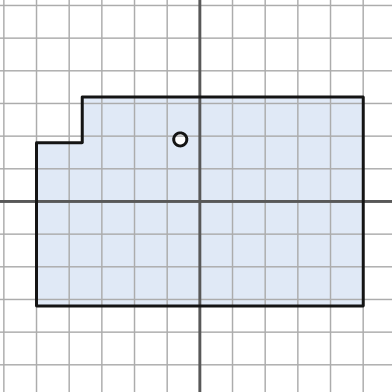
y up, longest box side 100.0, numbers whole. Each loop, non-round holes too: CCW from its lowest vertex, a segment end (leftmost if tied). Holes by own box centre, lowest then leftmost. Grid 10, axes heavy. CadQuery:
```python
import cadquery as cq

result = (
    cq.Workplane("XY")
    .moveTo(-50.0, -32.0)
    .lineTo(50.0, -32.0)
    .lineTo(50.0, 32.0)
    .lineTo(-36.0, 32.0)
    .lineTo(-36.0, 18.0)
    .lineTo(-50.0, 18.0)
    .close()
    .moveTo(-6.0, 19.0)
    .circle(2.0)
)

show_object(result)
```